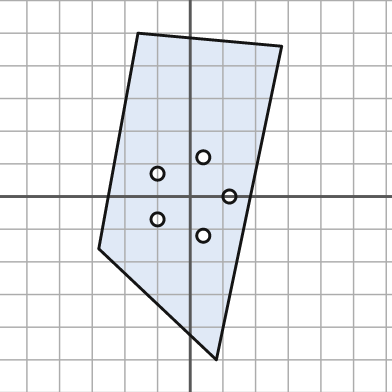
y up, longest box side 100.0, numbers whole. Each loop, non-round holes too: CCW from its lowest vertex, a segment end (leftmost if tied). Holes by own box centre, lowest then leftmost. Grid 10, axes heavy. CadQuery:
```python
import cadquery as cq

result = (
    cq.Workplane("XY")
    .moveTo(8.0, -50.0)
    .lineTo(28.0, 46.0)
    .lineTo(-16.0, 50.0)
    .lineTo(-28.0, -16.0)
    .close()
    .moveTo(4.0, -12.0)
    .circle(2.0)
    .moveTo(-10.0, -7.0)
    .circle(2.0)
    .moveTo(12.0, 0.0)
    .circle(2.0)
    .moveTo(-10.0, 7.0)
    .circle(2.0)
    .moveTo(4.0, 12.0)
    .circle(2.0)
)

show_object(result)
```